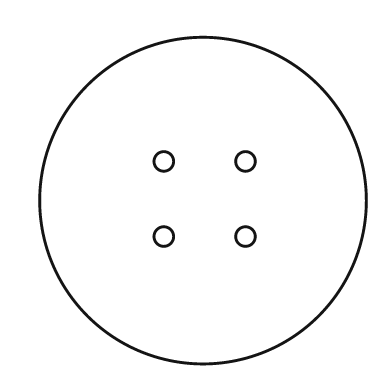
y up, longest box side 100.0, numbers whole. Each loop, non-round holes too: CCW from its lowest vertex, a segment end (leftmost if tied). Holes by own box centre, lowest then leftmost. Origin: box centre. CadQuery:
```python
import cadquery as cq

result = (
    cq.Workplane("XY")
    .moveTo(0.0, 0.0)
    .circle(50.0)
    .moveTo(-12.0, -11.0)
    .circle(3.0)
    .moveTo(13.0, -11.0)
    .circle(3.0)
    .moveTo(-12.0, 12.0)
    .circle(3.0)
    .moveTo(13.0, 12.0)
    .circle(3.0)
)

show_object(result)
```